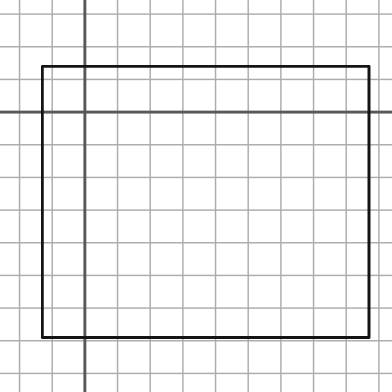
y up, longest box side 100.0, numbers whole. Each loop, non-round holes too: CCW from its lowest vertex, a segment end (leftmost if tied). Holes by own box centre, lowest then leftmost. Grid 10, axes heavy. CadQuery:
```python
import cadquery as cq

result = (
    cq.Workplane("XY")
    .moveTo(-13.0, -69.0)
    .lineTo(87.0, -69.0)
    .lineTo(87.0, 14.0)
    .lineTo(-13.0, 14.0)
    .close()
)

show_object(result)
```